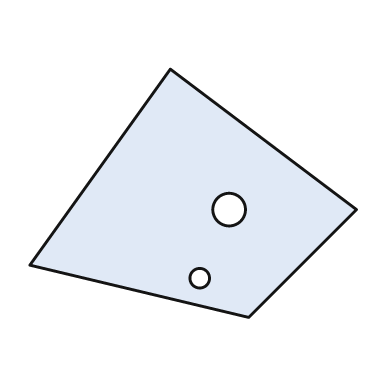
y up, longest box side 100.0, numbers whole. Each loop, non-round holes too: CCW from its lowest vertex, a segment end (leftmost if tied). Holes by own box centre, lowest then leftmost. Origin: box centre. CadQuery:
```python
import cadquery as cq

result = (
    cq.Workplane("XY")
    .moveTo(17.0, -38.0)
    .lineTo(50.0, -5.0)
    .lineTo(-7.0, 38.0)
    .lineTo(-50.0, -22.0)
    .close()
    .moveTo(2.0, -26.0)
    .circle(3.0)
    .moveTo(11.0, -5.0)
    .circle(5.0)
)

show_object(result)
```